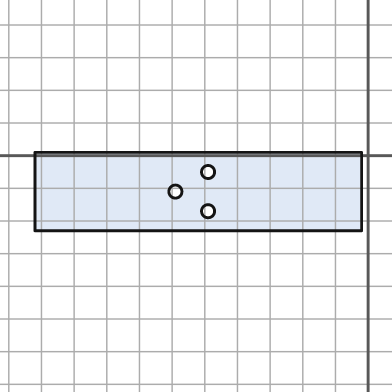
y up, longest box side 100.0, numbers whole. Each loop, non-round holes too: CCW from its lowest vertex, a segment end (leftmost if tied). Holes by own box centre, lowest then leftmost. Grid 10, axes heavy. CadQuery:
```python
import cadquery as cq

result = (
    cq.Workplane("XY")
    .moveTo(-102.0, -23.0)
    .lineTo(-2.0, -23.0)
    .lineTo(-2.0, 1.0)
    .lineTo(-102.0, 1.0)
    .close()
    .moveTo(-49.0, -17.0)
    .circle(2.0)
    .moveTo(-59.0, -11.0)
    .circle(2.0)
    .moveTo(-49.0, -5.0)
    .circle(2.0)
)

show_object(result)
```